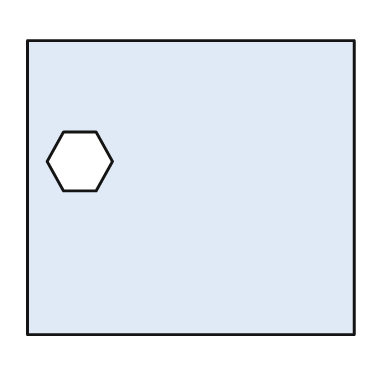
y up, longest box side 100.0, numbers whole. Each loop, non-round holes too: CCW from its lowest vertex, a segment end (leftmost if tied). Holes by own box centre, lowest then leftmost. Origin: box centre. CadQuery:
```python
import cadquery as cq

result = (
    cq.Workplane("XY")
    .moveTo(-50.0, -45.0)
    .lineTo(50.0, -45.0)
    .lineTo(50.0, 45.0)
    .lineTo(-50.0, 45.0)
    .close()
    .moveTo(-39.0, -1.0)
    .lineTo(-29.0, -1.0)
    .lineTo(-24.0, 8.0)
    .lineTo(-29.0, 17.0)
    .lineTo(-39.0, 17.0)
    .lineTo(-44.0, 8.0)
    .close()
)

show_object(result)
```